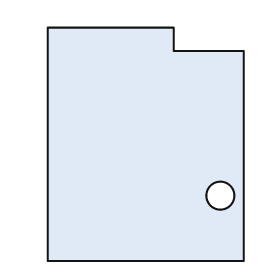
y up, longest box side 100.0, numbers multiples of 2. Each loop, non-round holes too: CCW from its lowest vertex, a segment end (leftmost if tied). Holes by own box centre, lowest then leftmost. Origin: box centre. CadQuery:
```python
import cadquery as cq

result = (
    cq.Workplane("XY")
    .moveTo(-42.0, -50.0)
    .lineTo(42.0, -50.0)
    .lineTo(42.0, 40.0)
    .lineTo(12.0, 40.0)
    .lineTo(12.0, 50.0)
    .lineTo(-42.0, 50.0)
    .close()
    .moveTo(32.0, -22.0)
    .circle(6.0)
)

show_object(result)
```